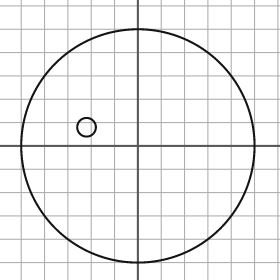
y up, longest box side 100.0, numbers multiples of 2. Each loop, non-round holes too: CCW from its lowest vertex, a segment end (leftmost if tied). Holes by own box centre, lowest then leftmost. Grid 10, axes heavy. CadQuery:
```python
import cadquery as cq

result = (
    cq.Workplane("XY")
    .moveTo(0.0, 0.0)
    .circle(50.0)
    .moveTo(-22.0, 8.0)
    .circle(4.0)
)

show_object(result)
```